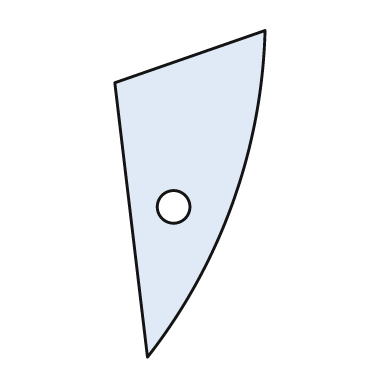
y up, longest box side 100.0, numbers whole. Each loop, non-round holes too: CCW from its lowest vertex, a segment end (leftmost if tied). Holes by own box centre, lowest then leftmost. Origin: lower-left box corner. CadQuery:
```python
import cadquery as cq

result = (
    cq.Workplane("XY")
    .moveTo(10.0, 0.0)
    .threePointArc((36.0, 47.0), (46.0, 100.0))
    .lineTo(0.0, 84.0)
    .close()
    .moveTo(18.0, 46.0)
    .circle(5.0)
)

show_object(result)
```